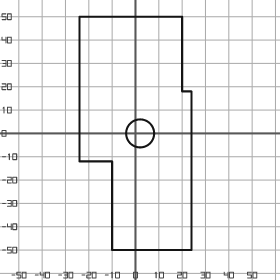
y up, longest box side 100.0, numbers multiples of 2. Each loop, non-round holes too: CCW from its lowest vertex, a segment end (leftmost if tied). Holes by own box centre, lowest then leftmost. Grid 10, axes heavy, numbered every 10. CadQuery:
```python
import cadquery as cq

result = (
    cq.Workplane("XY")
    .moveTo(-10.0, -50.0)
    .lineTo(24.0, -50.0)
    .lineTo(24.0, 18.0)
    .lineTo(20.0, 18.0)
    .lineTo(20.0, 50.0)
    .lineTo(-24.0, 50.0)
    .lineTo(-24.0, -12.0)
    .lineTo(-10.0, -12.0)
    .close()
    .moveTo(2.0, 0.0)
    .circle(6.0)
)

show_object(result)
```